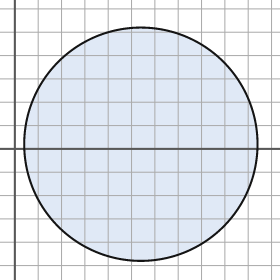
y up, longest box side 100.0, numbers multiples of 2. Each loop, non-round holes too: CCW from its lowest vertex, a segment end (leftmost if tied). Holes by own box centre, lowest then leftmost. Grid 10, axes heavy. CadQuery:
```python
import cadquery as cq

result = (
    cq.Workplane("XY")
    .moveTo(54.0, 2.0)
    .circle(50.0)
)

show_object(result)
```